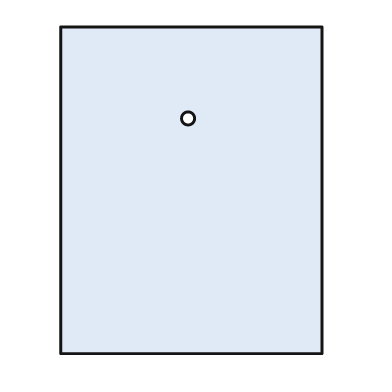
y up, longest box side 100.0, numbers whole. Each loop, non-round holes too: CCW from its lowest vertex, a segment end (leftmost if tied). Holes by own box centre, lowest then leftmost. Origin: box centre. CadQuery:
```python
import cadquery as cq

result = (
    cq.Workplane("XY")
    .moveTo(-40.0, -50.0)
    .lineTo(40.0, -50.0)
    .lineTo(40.0, 50.0)
    .lineTo(-40.0, 50.0)
    .close()
    .moveTo(-1.0, 22.0)
    .circle(2.0)
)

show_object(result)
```